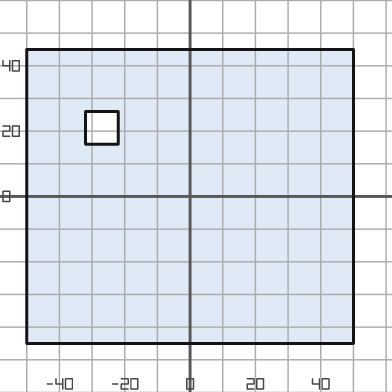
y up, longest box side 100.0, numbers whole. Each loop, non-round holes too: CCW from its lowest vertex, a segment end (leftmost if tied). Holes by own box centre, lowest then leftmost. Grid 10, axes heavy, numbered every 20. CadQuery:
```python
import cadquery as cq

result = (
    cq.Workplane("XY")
    .moveTo(-50.0, -45.0)
    .lineTo(50.0, -45.0)
    .lineTo(50.0, 45.0)
    .lineTo(-50.0, 45.0)
    .close()
    .moveTo(-32.0, 16.0)
    .lineTo(-22.0, 16.0)
    .lineTo(-22.0, 26.0)
    .lineTo(-32.0, 26.0)
    .close()
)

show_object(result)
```